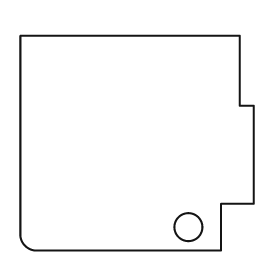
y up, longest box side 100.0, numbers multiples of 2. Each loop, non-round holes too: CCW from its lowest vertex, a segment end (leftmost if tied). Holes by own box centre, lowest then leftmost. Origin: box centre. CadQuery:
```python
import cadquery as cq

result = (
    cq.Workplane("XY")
    .moveTo(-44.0, -46.0)
    .lineTo(36.0, -46.0)
    .lineTo(36.0, -26.0)
    .lineTo(50.0, -26.0)
    .lineTo(50.0, 16.0)
    .lineTo(44.0, 16.0)
    .lineTo(44.0, 46.0)
    .lineTo(-50.0, 46.0)
    .lineTo(-50.0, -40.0)
    .threePointArc((-48.0, -44.0), (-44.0, -46.0))
    .close()
    .moveTo(22.0, -36.0)
    .circle(6.0)
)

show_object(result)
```